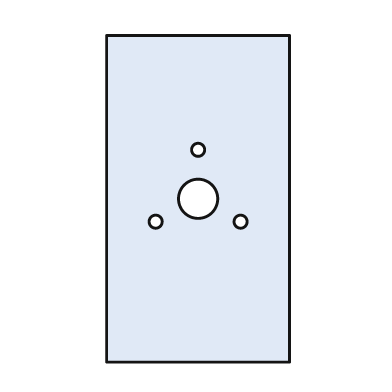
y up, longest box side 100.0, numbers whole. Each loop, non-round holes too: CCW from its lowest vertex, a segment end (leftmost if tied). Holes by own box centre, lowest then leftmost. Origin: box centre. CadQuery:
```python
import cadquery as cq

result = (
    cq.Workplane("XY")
    .moveTo(-28.0, -50.0)
    .lineTo(28.0, -50.0)
    .lineTo(28.0, 50.0)
    .lineTo(-28.0, 50.0)
    .close()
    .moveTo(-13.0, -7.0)
    .circle(2.0)
    .moveTo(13.0, -7.0)
    .circle(2.0)
    .moveTo(0.0, 0.0)
    .circle(6.0)
    .moveTo(0.0, 15.0)
    .circle(2.0)
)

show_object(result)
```